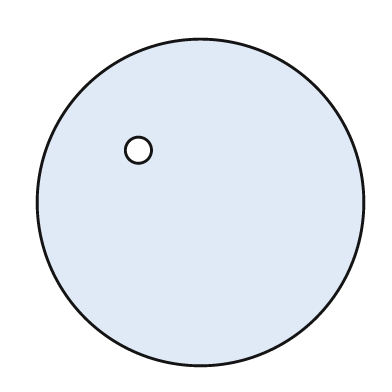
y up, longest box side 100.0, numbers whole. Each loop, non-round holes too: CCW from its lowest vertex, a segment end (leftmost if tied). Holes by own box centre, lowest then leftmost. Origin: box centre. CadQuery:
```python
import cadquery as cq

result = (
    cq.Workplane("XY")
    .moveTo(0.0, 0.0)
    .circle(50.0)
    .moveTo(-19.0, 16.0)
    .circle(4.0)
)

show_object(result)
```